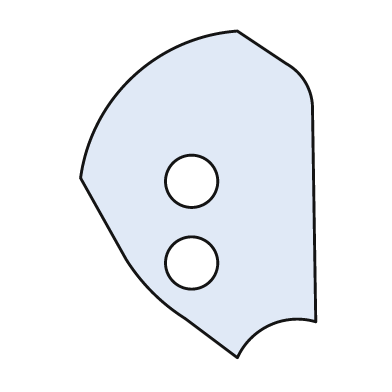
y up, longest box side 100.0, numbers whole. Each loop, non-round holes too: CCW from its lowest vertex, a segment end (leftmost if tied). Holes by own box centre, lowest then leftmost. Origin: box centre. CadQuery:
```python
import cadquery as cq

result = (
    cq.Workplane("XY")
    .moveTo(12.0, -50.0)
    .threePointArc((22.0, -40.0), (36.0, -39.0))
    .lineTo(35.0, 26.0)
    .threePointArc((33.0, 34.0), (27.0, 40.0))
    .lineTo(12.0, 50.0)
    .threePointArc((-20.0, 36.0), (-36.0, 5.0))
    .lineTo(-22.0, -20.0)
    .threePointArc((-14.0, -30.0), (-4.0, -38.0))
    .close()
    .moveTo(-2.0, -21.0)
    .circle(8.0)
    .moveTo(-2.0, 4.0)
    .circle(8.0)
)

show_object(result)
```